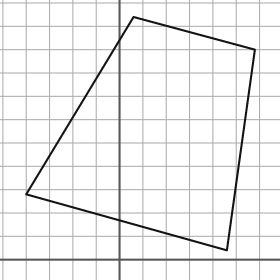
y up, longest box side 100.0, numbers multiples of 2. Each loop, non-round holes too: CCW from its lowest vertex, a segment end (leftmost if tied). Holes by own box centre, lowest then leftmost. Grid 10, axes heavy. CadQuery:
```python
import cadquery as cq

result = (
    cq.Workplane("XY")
    .moveTo(46.0, 4.0)
    .lineTo(58.0, 90.0)
    .lineTo(6.0, 104.0)
    .lineTo(-40.0, 28.0)
    .close()
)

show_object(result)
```